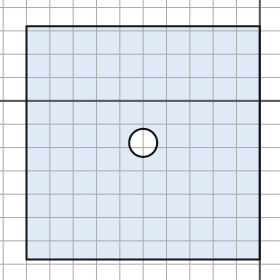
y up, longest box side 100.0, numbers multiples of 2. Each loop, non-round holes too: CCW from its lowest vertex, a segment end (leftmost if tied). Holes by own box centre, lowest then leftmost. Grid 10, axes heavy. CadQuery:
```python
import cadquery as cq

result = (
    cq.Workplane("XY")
    .moveTo(-100.0, -68.0)
    .lineTo(0.0, -68.0)
    .lineTo(0.0, 32.0)
    .lineTo(-100.0, 32.0)
    .close()
    .moveTo(-50.0, -18.0)
    .circle(6.0)
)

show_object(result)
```